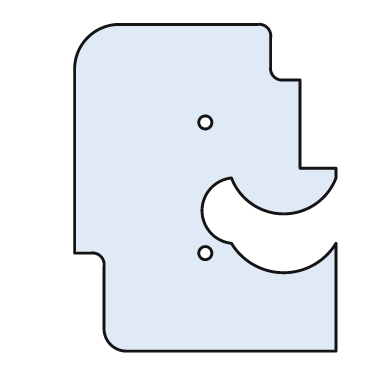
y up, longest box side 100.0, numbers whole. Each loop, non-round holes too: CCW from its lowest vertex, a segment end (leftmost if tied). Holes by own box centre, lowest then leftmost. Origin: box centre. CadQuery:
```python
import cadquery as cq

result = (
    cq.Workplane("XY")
    .moveTo(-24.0, -50.0)
    .lineTo(40.0, -50.0)
    .lineTo(40.0, -17.0)
    .threePointArc((24.0, -26.0), (8.0, -17.0))
    .threePointArc((-1.0, -7.0), (8.0, 3.0))
    .threePointArc((24.0, -8.0), (40.0, 3.0))
    .lineTo(40.0, 6.0)
    .lineTo(29.0, 6.0)
    .lineTo(29.0, 33.0)
    .lineTo(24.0, 33.0)
    .threePointArc((21.0, 34.0), (20.0, 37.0))
    .lineTo(20.0, 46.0)
    .threePointArc((19.0, 49.0), (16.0, 50.0))
    .lineTo(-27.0, 50.0)
    .threePointArc((-36.0, 46.0), (-40.0, 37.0))
    .lineTo(-40.0, -20.0)
    .lineTo(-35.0, -20.0)
    .threePointArc((-32.0, -21.0), (-31.0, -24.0))
    .lineTo(-31.0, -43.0)
    .threePointArc((-29.0, -48.0), (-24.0, -50.0))
    .close()
    .moveTo(0.0, -20.0)
    .circle(2.0)
    .moveTo(0.0, 20.0)
    .circle(2.0)
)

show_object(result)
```